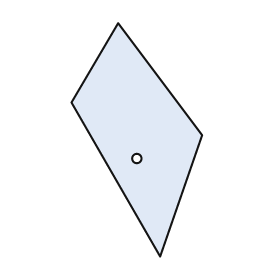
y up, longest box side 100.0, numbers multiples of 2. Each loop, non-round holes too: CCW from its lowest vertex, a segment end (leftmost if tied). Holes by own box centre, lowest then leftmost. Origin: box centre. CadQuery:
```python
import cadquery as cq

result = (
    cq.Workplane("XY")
    .moveTo(10.0, -50.0)
    .lineTo(28.0, 2.0)
    .lineTo(-8.0, 50.0)
    .lineTo(-28.0, 16.0)
    .close()
    .moveTo(0.0, -8.0)
    .circle(2.0)
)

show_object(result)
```